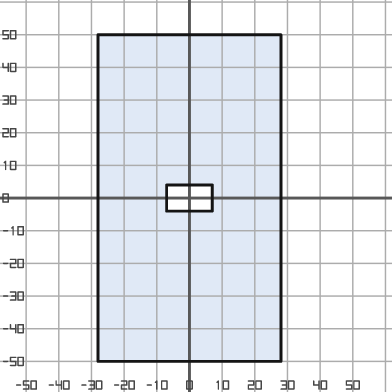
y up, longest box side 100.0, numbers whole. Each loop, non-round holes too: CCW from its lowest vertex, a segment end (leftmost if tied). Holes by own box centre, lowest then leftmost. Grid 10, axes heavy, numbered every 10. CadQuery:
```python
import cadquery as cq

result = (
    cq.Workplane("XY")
    .moveTo(-28.0, -50.0)
    .lineTo(28.0, -50.0)
    .lineTo(28.0, 50.0)
    .lineTo(-28.0, 50.0)
    .close()
    .moveTo(-7.0, -4.0)
    .lineTo(7.0, -4.0)
    .lineTo(7.0, 4.0)
    .lineTo(-7.0, 4.0)
    .close()
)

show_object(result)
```